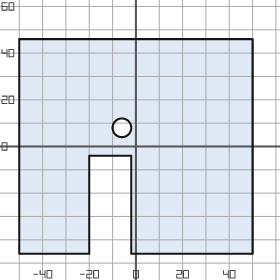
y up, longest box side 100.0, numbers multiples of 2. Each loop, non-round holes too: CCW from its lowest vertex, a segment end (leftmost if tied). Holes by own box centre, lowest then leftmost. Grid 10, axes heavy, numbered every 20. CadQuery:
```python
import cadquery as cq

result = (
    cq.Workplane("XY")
    .moveTo(-50.0, -46.0)
    .lineTo(-20.0, -46.0)
    .lineTo(-20.0, -4.0)
    .lineTo(-2.0, -4.0)
    .lineTo(-2.0, -46.0)
    .lineTo(50.0, -46.0)
    .lineTo(50.0, 46.0)
    .lineTo(-50.0, 46.0)
    .close()
    .moveTo(-6.0, 8.0)
    .circle(4.0)
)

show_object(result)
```